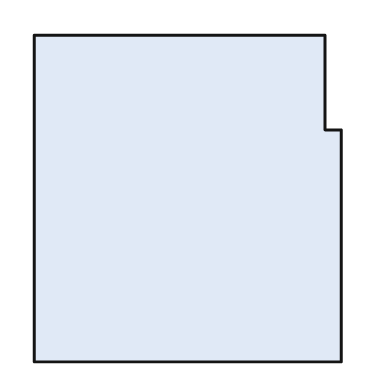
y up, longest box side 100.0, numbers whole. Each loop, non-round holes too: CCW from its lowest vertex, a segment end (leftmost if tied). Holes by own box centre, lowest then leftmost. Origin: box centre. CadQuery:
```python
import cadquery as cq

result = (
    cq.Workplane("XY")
    .moveTo(-47.0, -50.0)
    .lineTo(47.0, -50.0)
    .lineTo(47.0, 21.0)
    .lineTo(42.0, 21.0)
    .lineTo(42.0, 50.0)
    .lineTo(-47.0, 50.0)
    .close()
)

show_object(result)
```